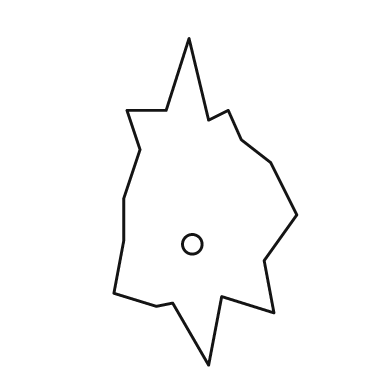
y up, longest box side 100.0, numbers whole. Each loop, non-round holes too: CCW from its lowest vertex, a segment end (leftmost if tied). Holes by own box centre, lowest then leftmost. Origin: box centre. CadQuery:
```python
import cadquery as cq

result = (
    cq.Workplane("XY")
    .moveTo(1.0, -50.0)
    .lineTo(5.0, -29.0)
    .lineTo(21.0, -34.0)
    .lineTo(18.0, -18.0)
    .lineTo(28.0, -4.0)
    .lineTo(20.0, 12.0)
    .lineTo(11.0, 19.0)
    .lineTo(7.0, 28.0)
    .lineTo(1.0, 25.0)
    .lineTo(-5.0, 50.0)
    .lineTo(-12.0, 28.0)
    .lineTo(-24.0, 28.0)
    .lineTo(-20.0, 16.0)
    .lineTo(-25.0, 1.0)
    .lineTo(-25.0, -12.0)
    .lineTo(-28.0, -28.0)
    .lineTo(-15.0, -32.0)
    .lineTo(-10.0, -31.0)
    .close()
    .moveTo(-4.0, -13.0)
    .circle(3.0)
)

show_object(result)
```